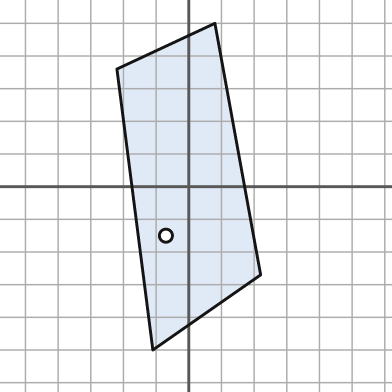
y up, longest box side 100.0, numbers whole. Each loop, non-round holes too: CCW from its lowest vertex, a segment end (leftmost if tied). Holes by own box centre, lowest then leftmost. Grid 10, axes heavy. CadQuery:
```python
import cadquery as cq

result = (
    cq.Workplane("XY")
    .moveTo(-11.0, -50.0)
    .lineTo(22.0, -27.0)
    .lineTo(8.0, 50.0)
    .lineTo(-22.0, 36.0)
    .close()
    .moveTo(-7.0, -15.0)
    .circle(2.0)
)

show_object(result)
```